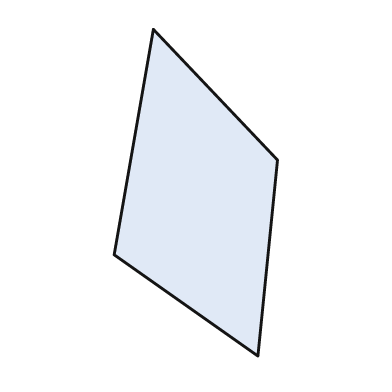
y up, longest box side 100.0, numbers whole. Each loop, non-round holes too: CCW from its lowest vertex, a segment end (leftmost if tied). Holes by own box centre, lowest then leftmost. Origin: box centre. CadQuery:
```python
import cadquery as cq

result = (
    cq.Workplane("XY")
    .moveTo(19.0, -50.0)
    .lineTo(25.0, 10.0)
    .lineTo(-13.0, 50.0)
    .lineTo(-25.0, -19.0)
    .close()
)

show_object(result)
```